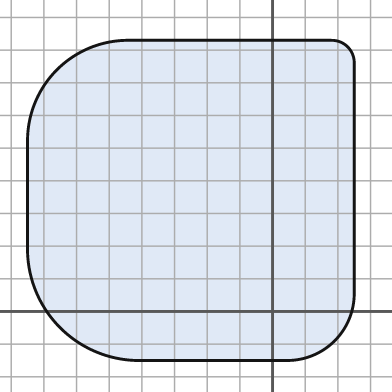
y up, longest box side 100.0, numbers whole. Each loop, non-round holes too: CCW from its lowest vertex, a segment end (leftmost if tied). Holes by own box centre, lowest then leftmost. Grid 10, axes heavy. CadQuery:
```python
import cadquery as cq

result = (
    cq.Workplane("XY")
    .moveTo(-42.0, -15.0)
    .lineTo(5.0, -15.0)
    .threePointArc((19.0, -9.0), (25.0, 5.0))
    .lineTo(25.0, 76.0)
    .threePointArc((23.0, 81.0), (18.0, 83.0))
    .lineTo(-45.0, 83.0)
    .threePointArc((-66.0, 74.0), (-75.0, 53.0))
    .lineTo(-75.0, 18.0)
    .threePointArc((-65.0, -5.0), (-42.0, -15.0))
    .close()
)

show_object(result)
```